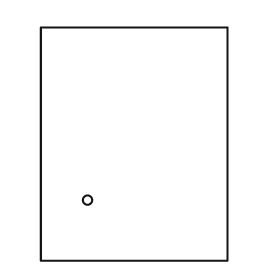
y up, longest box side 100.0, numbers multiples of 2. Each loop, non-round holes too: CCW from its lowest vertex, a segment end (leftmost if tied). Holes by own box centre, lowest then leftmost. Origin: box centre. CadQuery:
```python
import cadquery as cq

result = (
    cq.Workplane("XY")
    .moveTo(-40.0, -50.0)
    .lineTo(40.0, -50.0)
    .lineTo(40.0, 50.0)
    .lineTo(-40.0, 50.0)
    .close()
    .moveTo(-20.0, -24.0)
    .circle(2.0)
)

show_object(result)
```